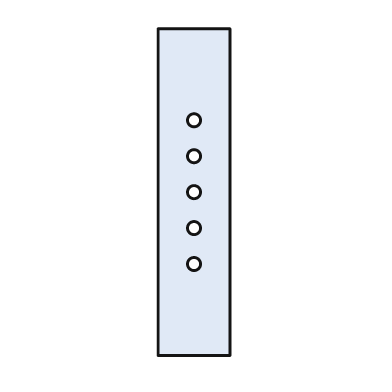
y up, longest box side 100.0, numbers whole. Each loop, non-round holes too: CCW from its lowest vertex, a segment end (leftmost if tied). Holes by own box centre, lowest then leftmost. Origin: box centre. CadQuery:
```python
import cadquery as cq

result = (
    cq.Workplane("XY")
    .moveTo(-11.0, -50.0)
    .lineTo(11.0, -50.0)
    .lineTo(11.0, 50.0)
    .lineTo(-11.0, 50.0)
    .close()
    .moveTo(0.0, -22.0)
    .circle(2.0)
    .moveTo(0.0, -11.0)
    .circle(2.0)
    .moveTo(0.0, 0.0)
    .circle(2.0)
    .moveTo(0.0, 11.0)
    .circle(2.0)
    .moveTo(0.0, 22.0)
    .circle(2.0)
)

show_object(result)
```